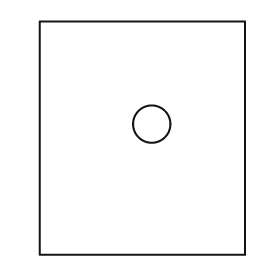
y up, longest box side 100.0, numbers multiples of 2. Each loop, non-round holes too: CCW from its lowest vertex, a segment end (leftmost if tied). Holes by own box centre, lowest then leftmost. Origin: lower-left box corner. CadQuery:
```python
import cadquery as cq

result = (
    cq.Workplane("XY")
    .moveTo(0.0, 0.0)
    .lineTo(88.0, 0.0)
    .lineTo(88.0, 100.0)
    .lineTo(0.0, 100.0)
    .close()
    .moveTo(48.0, 56.0)
    .circle(8.0)
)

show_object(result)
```